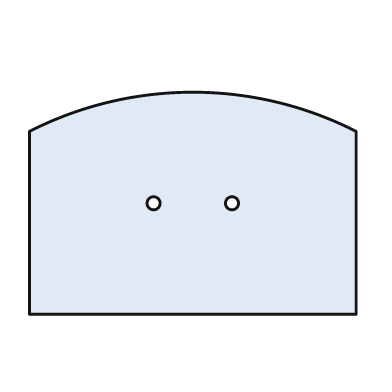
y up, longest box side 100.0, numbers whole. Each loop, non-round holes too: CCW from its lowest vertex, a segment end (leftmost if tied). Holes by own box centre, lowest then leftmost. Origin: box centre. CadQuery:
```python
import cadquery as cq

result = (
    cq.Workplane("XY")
    .moveTo(-50.0, -34.0)
    .lineTo(50.0, -34.0)
    .lineTo(50.0, 22.0)
    .threePointArc((0.0, 34.0), (-50.0, 22.0))
    .close()
    .moveTo(-12.0, 0.0)
    .circle(2.0)
    .moveTo(12.0, 0.0)
    .circle(2.0)
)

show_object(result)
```